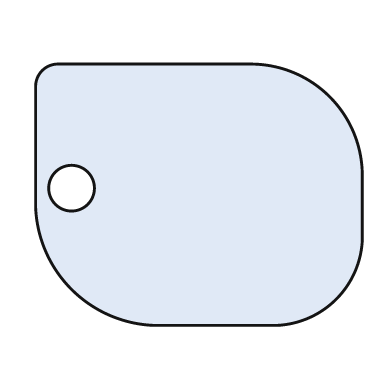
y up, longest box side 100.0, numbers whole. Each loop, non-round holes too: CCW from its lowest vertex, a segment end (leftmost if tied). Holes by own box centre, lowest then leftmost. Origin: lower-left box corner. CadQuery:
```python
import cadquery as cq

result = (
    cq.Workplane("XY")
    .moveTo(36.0, 0.0)
    .lineTo(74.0, 0.0)
    .threePointArc((92.0, 8.0), (100.0, 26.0))
    .lineTo(100.0, 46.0)
    .threePointArc((90.0, 70.0), (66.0, 80.0))
    .lineTo(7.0, 80.0)
    .threePointArc((2.0, 78.0), (0.0, 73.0))
    .lineTo(0.0, 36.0)
    .threePointArc((11.0, 11.0), (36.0, 0.0))
    .close()
    .moveTo(11.0, 42.0)
    .circle(7.0)
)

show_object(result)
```